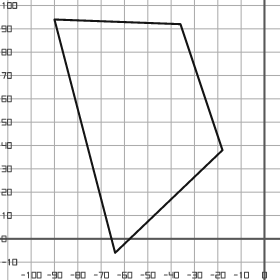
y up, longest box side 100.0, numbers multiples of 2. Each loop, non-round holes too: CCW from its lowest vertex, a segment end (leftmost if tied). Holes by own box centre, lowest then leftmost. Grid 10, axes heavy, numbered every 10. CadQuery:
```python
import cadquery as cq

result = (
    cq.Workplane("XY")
    .moveTo(-64.0, -6.0)
    .lineTo(-18.0, 38.0)
    .lineTo(-36.0, 92.0)
    .lineTo(-90.0, 94.0)
    .close()
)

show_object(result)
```